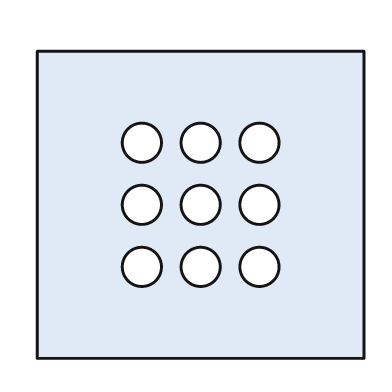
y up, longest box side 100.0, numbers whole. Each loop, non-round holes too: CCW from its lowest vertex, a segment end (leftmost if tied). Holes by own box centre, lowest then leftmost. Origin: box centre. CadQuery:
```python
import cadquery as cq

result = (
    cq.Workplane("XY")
    .moveTo(-50.0, -47.0)
    .lineTo(50.0, -47.0)
    .lineTo(50.0, 47.0)
    .lineTo(-50.0, 47.0)
    .close()
    .moveTo(-18.0, -19.0)
    .circle(6.0)
    .moveTo(0.0, -19.0)
    .circle(6.0)
    .moveTo(18.0, -19.0)
    .circle(6.0)
    .moveTo(-18.0, 0.0)
    .circle(6.0)
    .moveTo(0.0, 0.0)
    .circle(6.0)
    .moveTo(18.0, 0.0)
    .circle(6.0)
    .moveTo(-18.0, 19.0)
    .circle(6.0)
    .moveTo(0.0, 19.0)
    .circle(6.0)
    .moveTo(18.0, 19.0)
    .circle(6.0)
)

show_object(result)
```